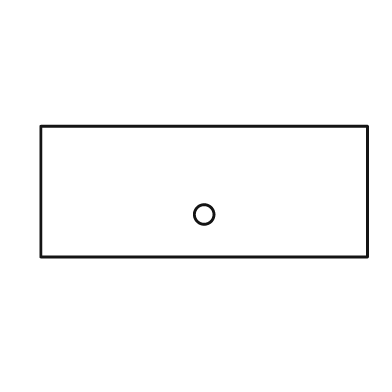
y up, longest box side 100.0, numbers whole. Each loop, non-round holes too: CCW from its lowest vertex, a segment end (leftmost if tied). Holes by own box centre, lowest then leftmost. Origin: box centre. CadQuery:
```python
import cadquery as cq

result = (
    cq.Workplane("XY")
    .moveTo(-50.0, -20.0)
    .lineTo(50.0, -20.0)
    .lineTo(50.0, 20.0)
    .lineTo(-50.0, 20.0)
    .close()
    .moveTo(0.0, -7.0)
    .circle(3.0)
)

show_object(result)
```